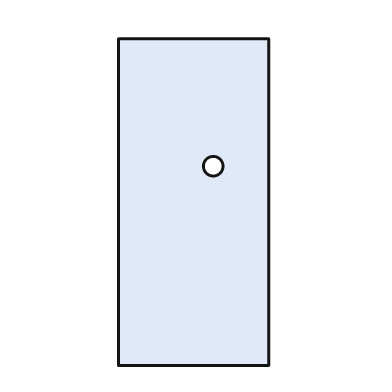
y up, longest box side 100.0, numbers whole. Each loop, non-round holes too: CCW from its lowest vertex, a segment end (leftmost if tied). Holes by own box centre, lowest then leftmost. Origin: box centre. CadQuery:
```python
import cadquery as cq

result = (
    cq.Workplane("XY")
    .moveTo(-23.0, -50.0)
    .lineTo(23.0, -50.0)
    .lineTo(23.0, 50.0)
    .lineTo(-23.0, 50.0)
    .close()
    .moveTo(6.0, 11.0)
    .circle(3.0)
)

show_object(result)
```